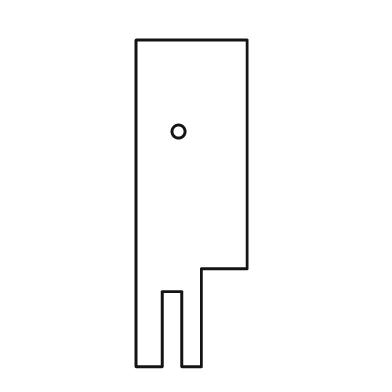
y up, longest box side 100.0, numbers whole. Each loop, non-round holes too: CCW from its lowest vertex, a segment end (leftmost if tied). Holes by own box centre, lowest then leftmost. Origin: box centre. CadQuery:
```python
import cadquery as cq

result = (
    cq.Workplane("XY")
    .moveTo(-17.0, -50.0)
    .lineTo(-9.0, -50.0)
    .lineTo(-9.0, -27.0)
    .lineTo(-3.0, -27.0)
    .lineTo(-3.0, -50.0)
    .lineTo(3.0, -50.0)
    .lineTo(3.0, -20.0)
    .lineTo(17.0, -20.0)
    .lineTo(17.0, 50.0)
    .lineTo(-17.0, 50.0)
    .close()
    .moveTo(-4.0, 22.0)
    .circle(2.0)
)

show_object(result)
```